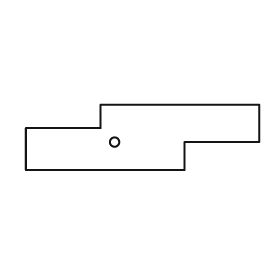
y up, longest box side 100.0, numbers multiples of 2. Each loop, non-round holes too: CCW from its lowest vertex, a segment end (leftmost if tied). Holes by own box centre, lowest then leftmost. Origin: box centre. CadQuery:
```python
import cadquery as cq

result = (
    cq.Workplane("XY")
    .moveTo(-50.0, -14.0)
    .lineTo(18.0, -14.0)
    .lineTo(18.0, -2.0)
    .lineTo(50.0, -2.0)
    .lineTo(50.0, 14.0)
    .lineTo(-18.0, 14.0)
    .lineTo(-18.0, 4.0)
    .lineTo(-50.0, 4.0)
    .close()
    .moveTo(-12.0, -2.0)
    .circle(2.0)
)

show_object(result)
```